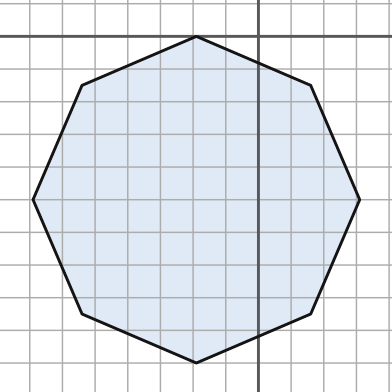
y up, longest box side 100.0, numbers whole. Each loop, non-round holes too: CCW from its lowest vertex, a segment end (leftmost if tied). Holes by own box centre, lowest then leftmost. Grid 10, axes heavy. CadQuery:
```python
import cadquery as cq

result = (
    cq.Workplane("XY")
    .moveTo(-19.0, -100.0)
    .lineTo(16.0, -85.0)
    .lineTo(31.0, -50.0)
    .lineTo(16.0, -15.0)
    .lineTo(-19.0, 0.0)
    .lineTo(-54.0, -15.0)
    .lineTo(-69.0, -50.0)
    .lineTo(-54.0, -85.0)
    .close()
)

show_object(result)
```